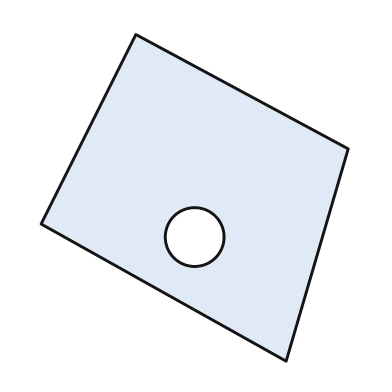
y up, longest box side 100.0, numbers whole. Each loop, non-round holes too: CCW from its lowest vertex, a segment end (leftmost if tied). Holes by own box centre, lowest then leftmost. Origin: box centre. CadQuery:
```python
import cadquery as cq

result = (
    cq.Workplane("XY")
    .moveTo(28.0, -50.0)
    .lineTo(47.0, 15.0)
    .lineTo(-18.0, 50.0)
    .lineTo(-47.0, -8.0)
    .close()
    .moveTo(0.0, -12.0)
    .circle(9.0)
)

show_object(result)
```